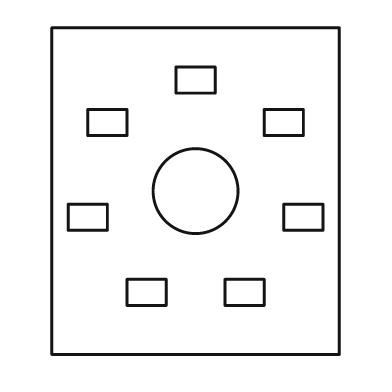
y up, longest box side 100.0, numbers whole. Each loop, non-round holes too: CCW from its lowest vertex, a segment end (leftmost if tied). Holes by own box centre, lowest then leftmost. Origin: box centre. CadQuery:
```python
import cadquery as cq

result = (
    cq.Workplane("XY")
    .moveTo(-44.0, -50.0)
    .lineTo(44.0, -50.0)
    .lineTo(44.0, 50.0)
    .lineTo(-44.0, 50.0)
    .close()
    .moveTo(-21.0, -35.0)
    .lineTo(-9.0, -35.0)
    .lineTo(-9.0, -27.0)
    .lineTo(-21.0, -27.0)
    .close()
    .moveTo(9.0, -35.0)
    .lineTo(21.0, -35.0)
    .lineTo(21.0, -27.0)
    .lineTo(9.0, -27.0)
    .close()
    .moveTo(-39.0, -12.0)
    .lineTo(-27.0, -12.0)
    .lineTo(-27.0, -4.0)
    .lineTo(-39.0, -4.0)
    .close()
    .moveTo(27.0, -12.0)
    .lineTo(39.0, -12.0)
    .lineTo(39.0, -4.0)
    .lineTo(27.0, -4.0)
    .close()
    .moveTo(0.0, 0.0)
    .circle(13.0)
    .moveTo(-33.0, 17.0)
    .lineTo(-21.0, 17.0)
    .lineTo(-21.0, 25.0)
    .lineTo(-33.0, 25.0)
    .close()
    .moveTo(21.0, 17.0)
    .lineTo(33.0, 17.0)
    .lineTo(33.0, 25.0)
    .lineTo(21.0, 25.0)
    .close()
    .moveTo(-6.0, 30.0)
    .lineTo(6.0, 30.0)
    .lineTo(6.0, 38.0)
    .lineTo(-6.0, 38.0)
    .close()
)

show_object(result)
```